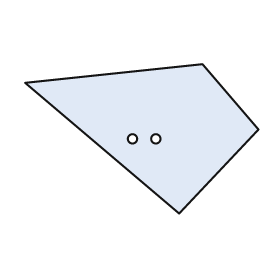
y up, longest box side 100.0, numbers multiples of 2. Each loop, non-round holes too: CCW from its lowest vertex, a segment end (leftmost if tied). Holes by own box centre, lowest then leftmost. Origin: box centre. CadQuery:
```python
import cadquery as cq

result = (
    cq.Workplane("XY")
    .moveTo(16.0, -32.0)
    .lineTo(50.0, 4.0)
    .lineTo(26.0, 32.0)
    .lineTo(-50.0, 24.0)
    .close()
    .moveTo(-4.0, 0.0)
    .circle(2.0)
    .moveTo(6.0, 0.0)
    .circle(2.0)
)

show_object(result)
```